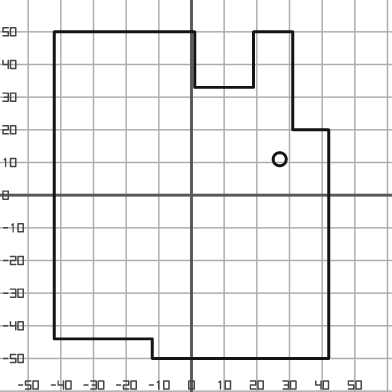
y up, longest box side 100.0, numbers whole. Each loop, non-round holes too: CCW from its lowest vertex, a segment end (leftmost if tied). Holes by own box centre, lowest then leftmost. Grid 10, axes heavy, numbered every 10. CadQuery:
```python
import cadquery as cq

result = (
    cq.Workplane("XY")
    .moveTo(-12.0, -50.0)
    .lineTo(42.0, -50.0)
    .lineTo(42.0, 20.0)
    .lineTo(31.0, 20.0)
    .lineTo(31.0, 50.0)
    .lineTo(19.0, 50.0)
    .lineTo(19.0, 33.0)
    .lineTo(1.0, 33.0)
    .lineTo(1.0, 50.0)
    .lineTo(-42.0, 50.0)
    .lineTo(-42.0, -44.0)
    .lineTo(-12.0, -44.0)
    .close()
    .moveTo(27.0, 11.0)
    .circle(2.0)
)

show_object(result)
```